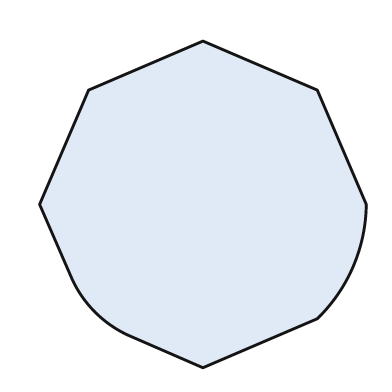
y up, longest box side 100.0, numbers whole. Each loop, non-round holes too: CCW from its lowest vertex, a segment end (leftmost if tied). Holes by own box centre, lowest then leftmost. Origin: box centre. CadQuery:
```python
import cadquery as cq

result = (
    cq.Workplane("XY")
    .moveTo(0.0, -50.0)
    .lineTo(35.0, -35.0)
    .threePointArc((46.0, -19.0), (50.0, 0.0))
    .lineTo(35.0, 35.0)
    .lineTo(0.0, 50.0)
    .lineTo(-35.0, 35.0)
    .lineTo(-50.0, 0.0)
    .lineTo(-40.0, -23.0)
    .threePointArc((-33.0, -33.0), (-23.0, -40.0))
    .close()
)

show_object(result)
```